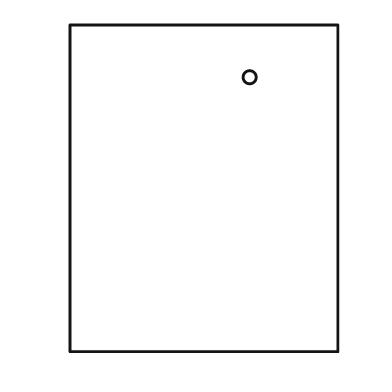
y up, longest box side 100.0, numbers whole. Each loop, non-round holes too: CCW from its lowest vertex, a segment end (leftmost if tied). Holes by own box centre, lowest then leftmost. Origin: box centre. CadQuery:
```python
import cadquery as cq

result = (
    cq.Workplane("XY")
    .moveTo(-41.0, -50.0)
    .lineTo(41.0, -50.0)
    .lineTo(41.0, 50.0)
    .lineTo(-41.0, 50.0)
    .close()
    .moveTo(14.0, 34.0)
    .circle(2.0)
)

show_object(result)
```